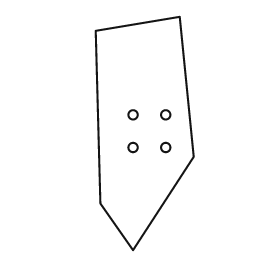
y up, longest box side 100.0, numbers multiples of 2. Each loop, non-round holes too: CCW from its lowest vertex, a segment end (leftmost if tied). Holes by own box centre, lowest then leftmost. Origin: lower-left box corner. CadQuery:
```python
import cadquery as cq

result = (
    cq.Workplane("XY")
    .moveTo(16.0, 0.0)
    .lineTo(42.0, 40.0)
    .lineTo(36.0, 100.0)
    .lineTo(0.0, 94.0)
    .lineTo(2.0, 20.0)
    .close()
    .moveTo(16.0, 44.0)
    .circle(2.0)
    .moveTo(30.0, 44.0)
    .circle(2.0)
    .moveTo(16.0, 58.0)
    .circle(2.0)
    .moveTo(30.0, 58.0)
    .circle(2.0)
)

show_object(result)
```